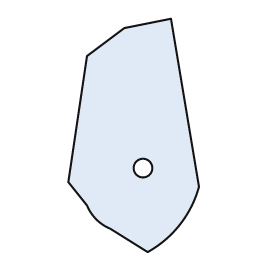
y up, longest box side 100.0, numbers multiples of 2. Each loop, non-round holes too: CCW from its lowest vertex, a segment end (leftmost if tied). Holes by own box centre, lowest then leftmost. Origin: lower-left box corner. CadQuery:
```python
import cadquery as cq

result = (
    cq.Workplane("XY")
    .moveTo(34.0, 0.0)
    .threePointArc((48.0, 12.0), (56.0, 28.0))
    .lineTo(44.0, 100.0)
    .lineTo(24.0, 96.0)
    .lineTo(8.0, 84.0)
    .lineTo(0.0, 30.0)
    .lineTo(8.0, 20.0)
    .threePointArc((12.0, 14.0), (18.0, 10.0))
    .close()
    .moveTo(32.0, 36.0)
    .circle(4.0)
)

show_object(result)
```